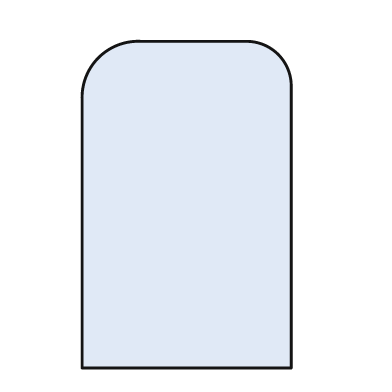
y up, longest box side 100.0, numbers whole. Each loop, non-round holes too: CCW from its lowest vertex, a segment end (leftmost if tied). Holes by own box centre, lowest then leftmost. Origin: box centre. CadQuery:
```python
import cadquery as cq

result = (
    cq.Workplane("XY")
    .moveTo(-32.0, -50.0)
    .lineTo(32.0, -50.0)
    .lineTo(32.0, 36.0)
    .threePointArc((28.0, 46.0), (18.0, 50.0))
    .lineTo(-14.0, 50.0)
    .threePointArc((-27.0, 45.0), (-32.0, 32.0))
    .close()
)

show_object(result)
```